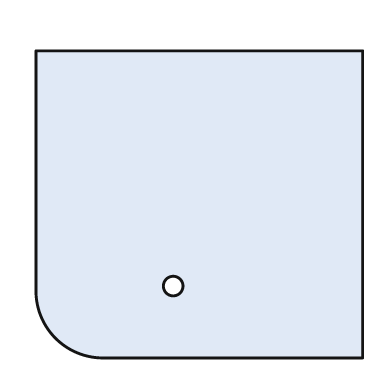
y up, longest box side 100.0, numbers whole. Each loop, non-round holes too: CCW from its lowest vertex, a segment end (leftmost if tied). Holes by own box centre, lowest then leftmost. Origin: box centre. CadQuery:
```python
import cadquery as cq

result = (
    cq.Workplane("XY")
    .moveTo(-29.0, -47.0)
    .lineTo(50.0, -47.0)
    .lineTo(50.0, 47.0)
    .lineTo(-50.0, 47.0)
    .lineTo(-50.0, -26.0)
    .threePointArc((-44.0, -41.0), (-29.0, -47.0))
    .close()
    .moveTo(-8.0, -25.0)
    .circle(3.0)
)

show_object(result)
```